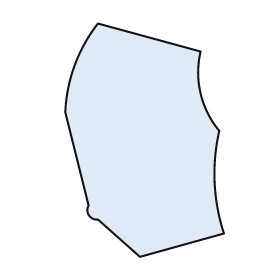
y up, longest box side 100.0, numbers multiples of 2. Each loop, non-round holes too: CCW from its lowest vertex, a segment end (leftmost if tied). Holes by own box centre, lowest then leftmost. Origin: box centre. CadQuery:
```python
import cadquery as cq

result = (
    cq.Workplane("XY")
    .moveTo(-2.0, -50.0)
    .lineTo(34.0, -40.0)
    .threePointArc((30.0, -18.0), (32.0, 4.0))
    .threePointArc((24.0, 20.0), (24.0, 38.0))
    .lineTo(-20.0, 50.0)
    .threePointArc((-30.0, 32.0), (-34.0, 12.0))
    .lineTo(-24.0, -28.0)
    .threePointArc((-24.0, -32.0), (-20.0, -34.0))
    .close()
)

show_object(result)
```